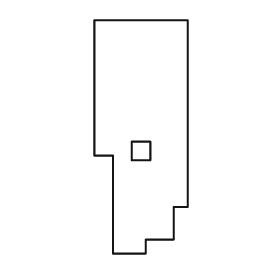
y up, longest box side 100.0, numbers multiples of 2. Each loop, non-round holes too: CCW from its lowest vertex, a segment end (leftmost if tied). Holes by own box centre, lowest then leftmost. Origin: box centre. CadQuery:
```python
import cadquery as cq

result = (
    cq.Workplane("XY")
    .moveTo(-12.0, -50.0)
    .lineTo(2.0, -50.0)
    .lineTo(2.0, -44.0)
    .lineTo(14.0, -44.0)
    .lineTo(14.0, -30.0)
    .lineTo(20.0, -30.0)
    .lineTo(20.0, 50.0)
    .lineTo(-20.0, 50.0)
    .lineTo(-20.0, -8.0)
    .lineTo(-12.0, -8.0)
    .close()
    .moveTo(-4.0, -10.0)
    .lineTo(4.0, -10.0)
    .lineTo(4.0, -2.0)
    .lineTo(-4.0, -2.0)
    .close()
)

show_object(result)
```